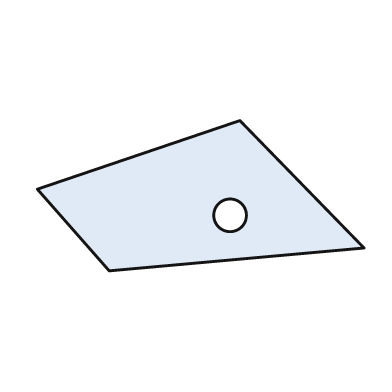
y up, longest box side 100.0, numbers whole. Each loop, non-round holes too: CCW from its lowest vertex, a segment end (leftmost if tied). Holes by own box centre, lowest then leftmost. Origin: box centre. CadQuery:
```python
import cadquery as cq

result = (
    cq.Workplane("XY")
    .moveTo(-28.0, -23.0)
    .lineTo(50.0, -16.0)
    .lineTo(12.0, 23.0)
    .lineTo(-50.0, 2.0)
    .close()
    .moveTo(9.0, -6.0)
    .circle(5.0)
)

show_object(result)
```